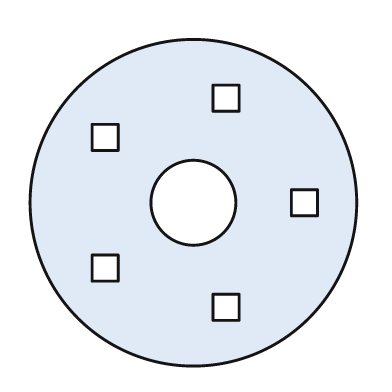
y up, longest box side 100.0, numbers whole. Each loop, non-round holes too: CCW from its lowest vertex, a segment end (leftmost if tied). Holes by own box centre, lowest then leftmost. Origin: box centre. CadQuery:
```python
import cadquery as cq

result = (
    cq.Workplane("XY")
    .moveTo(0.0, 0.0)
    .circle(50.0)
    .moveTo(6.0, -36.0)
    .lineTo(14.0, -36.0)
    .lineTo(14.0, -28.0)
    .lineTo(6.0, -28.0)
    .close()
    .moveTo(-31.0, -24.0)
    .lineTo(-23.0, -24.0)
    .lineTo(-23.0, -16.0)
    .lineTo(-31.0, -16.0)
    .close()
    .moveTo(0.0, 0.0)
    .circle(13.0)
    .moveTo(30.0, -4.0)
    .lineTo(38.0, -4.0)
    .lineTo(38.0, 4.0)
    .lineTo(30.0, 4.0)
    .close()
    .moveTo(-31.0, 16.0)
    .lineTo(-23.0, 16.0)
    .lineTo(-23.0, 24.0)
    .lineTo(-31.0, 24.0)
    .close()
    .moveTo(6.0, 28.0)
    .lineTo(14.0, 28.0)
    .lineTo(14.0, 36.0)
    .lineTo(6.0, 36.0)
    .close()
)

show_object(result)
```